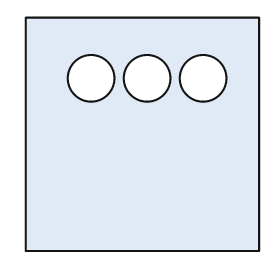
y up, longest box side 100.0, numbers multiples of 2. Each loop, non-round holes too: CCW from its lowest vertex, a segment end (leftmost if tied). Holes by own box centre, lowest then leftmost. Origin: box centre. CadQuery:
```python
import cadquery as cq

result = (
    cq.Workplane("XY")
    .moveTo(-50.0, -50.0)
    .lineTo(50.0, -50.0)
    .lineTo(50.0, 50.0)
    .lineTo(-50.0, 50.0)
    .close()
    .moveTo(-22.0, 24.0)
    .circle(10.0)
    .moveTo(2.0, 24.0)
    .circle(10.0)
    .moveTo(26.0, 24.0)
    .circle(10.0)
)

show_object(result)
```